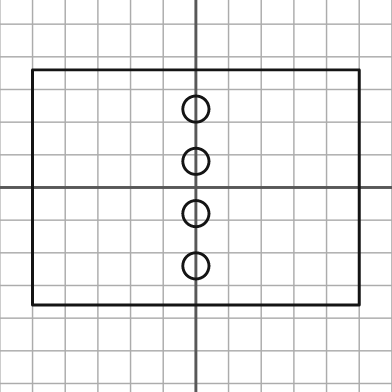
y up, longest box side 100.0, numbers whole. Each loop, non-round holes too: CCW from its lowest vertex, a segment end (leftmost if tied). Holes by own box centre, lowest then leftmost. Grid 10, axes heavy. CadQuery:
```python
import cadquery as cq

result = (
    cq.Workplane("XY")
    .moveTo(-50.0, -36.0)
    .lineTo(50.0, -36.0)
    .lineTo(50.0, 36.0)
    .lineTo(-50.0, 36.0)
    .close()
    .moveTo(0.0, -24.0)
    .circle(4.0)
    .moveTo(0.0, -8.0)
    .circle(4.0)
    .moveTo(0.0, 8.0)
    .circle(4.0)
    .moveTo(0.0, 24.0)
    .circle(4.0)
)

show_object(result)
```